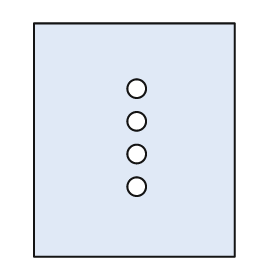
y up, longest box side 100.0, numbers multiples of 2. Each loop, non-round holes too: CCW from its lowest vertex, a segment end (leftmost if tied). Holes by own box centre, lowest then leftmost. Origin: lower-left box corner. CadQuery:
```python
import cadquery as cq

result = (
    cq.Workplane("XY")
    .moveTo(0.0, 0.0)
    .lineTo(86.0, 0.0)
    .lineTo(86.0, 100.0)
    .lineTo(0.0, 100.0)
    .close()
    .moveTo(44.0, 30.0)
    .circle(4.0)
    .moveTo(44.0, 44.0)
    .circle(4.0)
    .moveTo(44.0, 58.0)
    .circle(4.0)
    .moveTo(44.0, 72.0)
    .circle(4.0)
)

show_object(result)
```